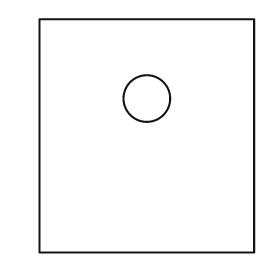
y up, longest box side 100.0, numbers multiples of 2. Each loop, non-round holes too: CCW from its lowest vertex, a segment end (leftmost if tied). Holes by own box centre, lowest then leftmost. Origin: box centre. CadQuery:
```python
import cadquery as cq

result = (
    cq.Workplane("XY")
    .moveTo(-46.0, -50.0)
    .lineTo(46.0, -50.0)
    .lineTo(46.0, 50.0)
    .lineTo(-46.0, 50.0)
    .close()
    .moveTo(0.0, 16.0)
    .circle(10.0)
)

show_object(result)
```